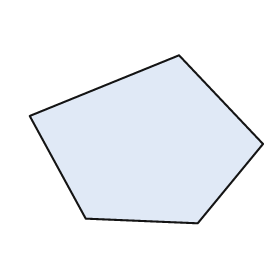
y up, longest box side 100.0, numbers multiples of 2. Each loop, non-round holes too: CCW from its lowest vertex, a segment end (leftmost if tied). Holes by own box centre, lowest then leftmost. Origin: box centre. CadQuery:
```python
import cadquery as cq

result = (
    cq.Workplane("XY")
    .moveTo(22.0, -36.0)
    .lineTo(50.0, -2.0)
    .lineTo(14.0, 36.0)
    .lineTo(-50.0, 10.0)
    .lineTo(-26.0, -34.0)
    .close()
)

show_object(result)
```